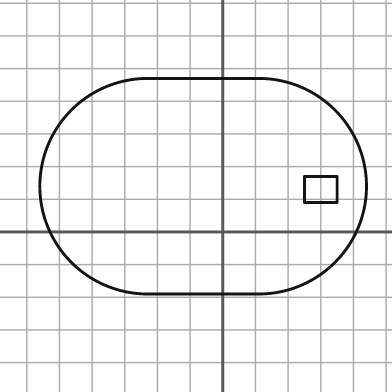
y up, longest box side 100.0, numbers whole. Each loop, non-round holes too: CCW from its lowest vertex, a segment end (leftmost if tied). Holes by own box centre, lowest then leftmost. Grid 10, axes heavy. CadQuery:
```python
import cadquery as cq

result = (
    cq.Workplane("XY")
    .moveTo(-23.0, -19.0)
    .lineTo(11.0, -19.0)
    .threePointArc((44.0, 14.0), (11.0, 47.0))
    .lineTo(-23.0, 47.0)
    .threePointArc((-56.0, 14.0), (-23.0, -19.0))
    .close()
    .moveTo(25.0, 9.0)
    .lineTo(35.0, 9.0)
    .lineTo(35.0, 17.0)
    .lineTo(25.0, 17.0)
    .close()
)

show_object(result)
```